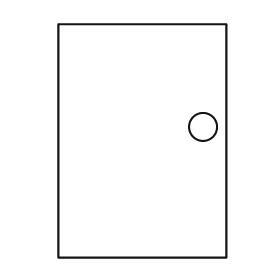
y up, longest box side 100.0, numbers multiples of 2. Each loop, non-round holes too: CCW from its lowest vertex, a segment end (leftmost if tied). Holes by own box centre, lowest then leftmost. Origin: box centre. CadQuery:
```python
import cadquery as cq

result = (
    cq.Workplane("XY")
    .moveTo(-36.0, -50.0)
    .lineTo(36.0, -50.0)
    .lineTo(36.0, 50.0)
    .lineTo(-36.0, 50.0)
    .close()
    .moveTo(26.0, 6.0)
    .circle(6.0)
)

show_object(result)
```